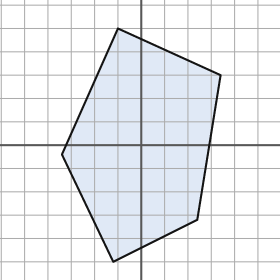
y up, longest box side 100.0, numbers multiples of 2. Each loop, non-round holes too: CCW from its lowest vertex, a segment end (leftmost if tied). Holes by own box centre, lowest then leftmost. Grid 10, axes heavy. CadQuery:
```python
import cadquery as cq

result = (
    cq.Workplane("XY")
    .moveTo(-12.0, -50.0)
    .lineTo(24.0, -32.0)
    .lineTo(34.0, 30.0)
    .lineTo(-10.0, 50.0)
    .lineTo(-34.0, -4.0)
    .close()
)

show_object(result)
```